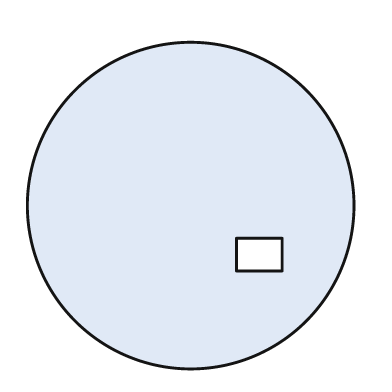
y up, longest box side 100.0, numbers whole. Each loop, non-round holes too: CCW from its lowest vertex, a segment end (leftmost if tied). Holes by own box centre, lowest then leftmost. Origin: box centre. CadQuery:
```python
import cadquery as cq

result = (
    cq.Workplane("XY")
    .moveTo(0.0, 0.0)
    .circle(50.0)
    .moveTo(14.0, -20.0)
    .lineTo(28.0, -20.0)
    .lineTo(28.0, -10.0)
    .lineTo(14.0, -10.0)
    .close()
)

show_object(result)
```